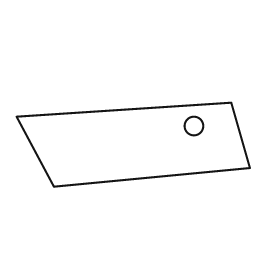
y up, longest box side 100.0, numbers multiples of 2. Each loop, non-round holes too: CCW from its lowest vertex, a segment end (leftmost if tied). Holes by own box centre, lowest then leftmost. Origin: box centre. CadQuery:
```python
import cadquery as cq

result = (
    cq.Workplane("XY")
    .moveTo(-34.0, -18.0)
    .lineTo(50.0, -10.0)
    .lineTo(42.0, 18.0)
    .lineTo(-50.0, 12.0)
    .close()
    .moveTo(26.0, 8.0)
    .circle(4.0)
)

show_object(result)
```